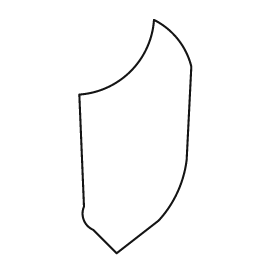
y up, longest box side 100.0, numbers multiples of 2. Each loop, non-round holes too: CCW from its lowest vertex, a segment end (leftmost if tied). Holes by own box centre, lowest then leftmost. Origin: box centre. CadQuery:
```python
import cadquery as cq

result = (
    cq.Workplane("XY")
    .moveTo(-8.0, -50.0)
    .lineTo(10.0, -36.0)
    .threePointArc((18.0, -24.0), (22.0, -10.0))
    .lineTo(24.0, 30.0)
    .threePointArc((18.0, 42.0), (8.0, 50.0))
    .threePointArc((-2.0, 28.0), (-24.0, 18.0))
    .lineTo(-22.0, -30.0)
    .threePointArc((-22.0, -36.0), (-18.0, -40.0))
    .close()
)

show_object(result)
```